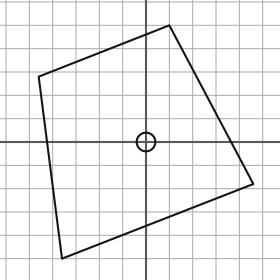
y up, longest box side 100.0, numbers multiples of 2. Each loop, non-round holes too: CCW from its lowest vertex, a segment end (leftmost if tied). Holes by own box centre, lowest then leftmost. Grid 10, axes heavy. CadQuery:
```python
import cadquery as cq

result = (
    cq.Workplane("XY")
    .moveTo(-36.0, -50.0)
    .lineTo(46.0, -18.0)
    .lineTo(10.0, 50.0)
    .lineTo(-46.0, 28.0)
    .close()
    .moveTo(0.0, 0.0)
    .circle(4.0)
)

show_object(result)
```